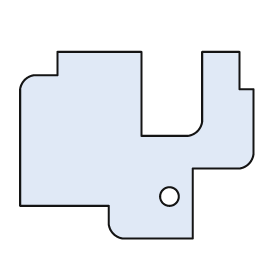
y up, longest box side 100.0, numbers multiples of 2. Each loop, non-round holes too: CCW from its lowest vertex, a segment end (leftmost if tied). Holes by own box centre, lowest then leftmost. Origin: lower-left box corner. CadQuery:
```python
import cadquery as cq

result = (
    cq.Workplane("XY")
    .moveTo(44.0, 0.0)
    .lineTo(74.0, 0.0)
    .lineTo(74.0, 30.0)
    .lineTo(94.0, 30.0)
    .threePointArc((98.0, 32.0), (100.0, 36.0))
    .lineTo(100.0, 64.0)
    .lineTo(94.0, 64.0)
    .lineTo(94.0, 80.0)
    .lineTo(78.0, 80.0)
    .lineTo(78.0, 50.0)
    .threePointArc((76.0, 46.0), (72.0, 44.0))
    .lineTo(52.0, 44.0)
    .lineTo(52.0, 80.0)
    .lineTo(16.0, 80.0)
    .lineTo(16.0, 70.0)
    .lineTo(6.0, 70.0)
    .threePointArc((2.0, 68.0), (0.0, 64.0))
    .lineTo(0.0, 14.0)
    .lineTo(38.0, 14.0)
    .lineTo(38.0, 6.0)
    .threePointArc((40.0, 2.0), (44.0, 0.0))
    .close()
    .moveTo(64.0, 18.0)
    .circle(4.0)
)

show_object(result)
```